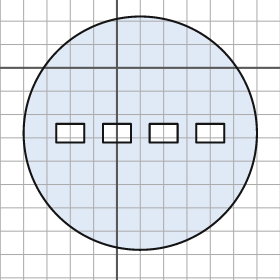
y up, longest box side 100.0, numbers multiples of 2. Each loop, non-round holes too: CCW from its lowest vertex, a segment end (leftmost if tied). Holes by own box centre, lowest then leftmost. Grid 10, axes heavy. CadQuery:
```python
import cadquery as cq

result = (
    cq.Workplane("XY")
    .moveTo(10.0, -28.0)
    .circle(50.0)
    .moveTo(-26.0, -32.0)
    .lineTo(-14.0, -32.0)
    .lineTo(-14.0, -24.0)
    .lineTo(-26.0, -24.0)
    .close()
    .moveTo(-6.0, -32.0)
    .lineTo(6.0, -32.0)
    .lineTo(6.0, -24.0)
    .lineTo(-6.0, -24.0)
    .close()
    .moveTo(14.0, -32.0)
    .lineTo(26.0, -32.0)
    .lineTo(26.0, -24.0)
    .lineTo(14.0, -24.0)
    .close()
    .moveTo(34.0, -32.0)
    .lineTo(46.0, -32.0)
    .lineTo(46.0, -24.0)
    .lineTo(34.0, -24.0)
    .close()
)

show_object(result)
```